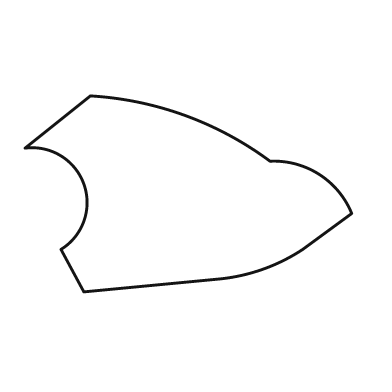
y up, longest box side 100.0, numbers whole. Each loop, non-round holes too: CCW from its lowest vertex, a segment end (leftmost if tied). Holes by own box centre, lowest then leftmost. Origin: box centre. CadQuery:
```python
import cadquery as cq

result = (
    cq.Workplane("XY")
    .moveTo(-32.0, -30.0)
    .lineTo(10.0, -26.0)
    .threePointArc((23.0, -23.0), (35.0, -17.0))
    .lineTo(50.0, -6.0)
    .threePointArc((40.0, 6.0), (25.0, 10.0))
    .threePointArc((-1.0, 24.0), (-30.0, 30.0))
    .lineTo(-50.0, 14.0)
    .threePointArc((-32.0, 3.0), (-39.0, -17.0))
    .close()
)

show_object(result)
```